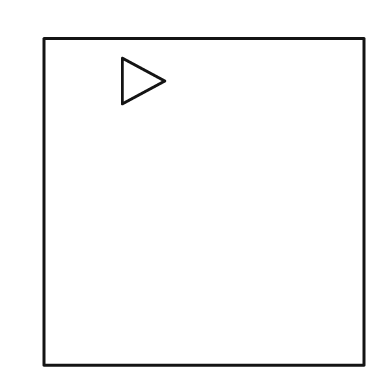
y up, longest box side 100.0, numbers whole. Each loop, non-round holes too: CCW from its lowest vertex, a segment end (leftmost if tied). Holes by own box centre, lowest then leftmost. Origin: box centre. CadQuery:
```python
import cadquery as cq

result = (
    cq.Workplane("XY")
    .moveTo(-49.0, -50.0)
    .lineTo(49.0, -50.0)
    .lineTo(49.0, 50.0)
    .lineTo(-49.0, 50.0)
    .close()
    .moveTo(-25.0, 30.0)
    .lineTo(-12.0, 37.0)
    .lineTo(-25.0, 44.0)
    .close()
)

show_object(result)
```